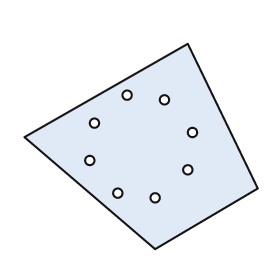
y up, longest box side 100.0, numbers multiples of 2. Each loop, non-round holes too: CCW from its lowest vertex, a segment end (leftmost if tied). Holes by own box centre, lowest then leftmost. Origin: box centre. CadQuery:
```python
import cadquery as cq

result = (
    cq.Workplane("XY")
    .moveTo(6.0, -44.0)
    .lineTo(50.0, -18.0)
    .lineTo(20.0, 44.0)
    .lineTo(-50.0, 4.0)
    .close()
    .moveTo(6.0, -22.0)
    .circle(2.0)
    .moveTo(-10.0, -20.0)
    .circle(2.0)
    .moveTo(20.0, -10.0)
    .circle(2.0)
    .moveTo(-22.0, -6.0)
    .circle(2.0)
    .moveTo(22.0, 6.0)
    .circle(2.0)
    .moveTo(-20.0, 10.0)
    .circle(2.0)
    .moveTo(10.0, 20.0)
    .circle(2.0)
    .moveTo(-6.0, 22.0)
    .circle(2.0)
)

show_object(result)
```